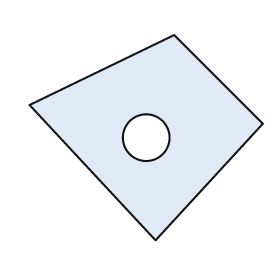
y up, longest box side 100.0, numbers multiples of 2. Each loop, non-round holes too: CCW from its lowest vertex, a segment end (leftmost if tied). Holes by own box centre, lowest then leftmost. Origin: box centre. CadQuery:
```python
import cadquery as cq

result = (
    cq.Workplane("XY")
    .moveTo(4.0, -44.0)
    .lineTo(50.0, 6.0)
    .lineTo(12.0, 44.0)
    .lineTo(-50.0, 14.0)
    .close()
    .moveTo(0.0, 0.0)
    .circle(10.0)
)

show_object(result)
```